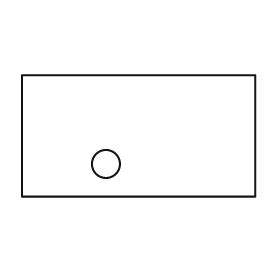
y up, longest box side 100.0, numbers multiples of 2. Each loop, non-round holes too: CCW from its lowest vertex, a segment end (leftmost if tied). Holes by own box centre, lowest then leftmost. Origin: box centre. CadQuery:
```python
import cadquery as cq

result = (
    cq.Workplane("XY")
    .moveTo(-50.0, -26.0)
    .lineTo(50.0, -26.0)
    .lineTo(50.0, 26.0)
    .lineTo(-50.0, 26.0)
    .close()
    .moveTo(-14.0, -12.0)
    .circle(6.0)
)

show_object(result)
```